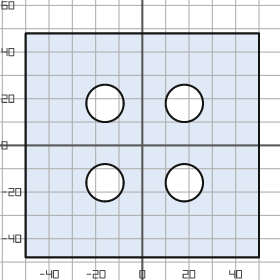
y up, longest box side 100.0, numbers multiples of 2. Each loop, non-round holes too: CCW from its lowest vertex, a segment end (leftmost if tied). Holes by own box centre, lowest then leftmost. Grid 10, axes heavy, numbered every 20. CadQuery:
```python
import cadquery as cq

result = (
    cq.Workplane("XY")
    .moveTo(-50.0, -48.0)
    .lineTo(50.0, -48.0)
    .lineTo(50.0, 48.0)
    .lineTo(-50.0, 48.0)
    .close()
    .moveTo(-16.0, -16.0)
    .circle(8.0)
    .moveTo(18.0, -16.0)
    .circle(8.0)
    .moveTo(-16.0, 18.0)
    .circle(8.0)
    .moveTo(18.0, 18.0)
    .circle(8.0)
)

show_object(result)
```